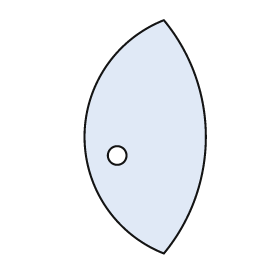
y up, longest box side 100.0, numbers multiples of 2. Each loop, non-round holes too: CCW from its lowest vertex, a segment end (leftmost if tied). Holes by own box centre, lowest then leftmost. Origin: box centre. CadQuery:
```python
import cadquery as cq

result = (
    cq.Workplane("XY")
    .moveTo(8.0, -50.0)
    .threePointArc((26.0, 0.0), (8.0, 50.0))
    .threePointArc((-26.0, 0.0), (8.0, -50.0))
    .close()
    .moveTo(-12.0, -8.0)
    .circle(4.0)
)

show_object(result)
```